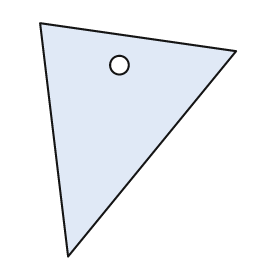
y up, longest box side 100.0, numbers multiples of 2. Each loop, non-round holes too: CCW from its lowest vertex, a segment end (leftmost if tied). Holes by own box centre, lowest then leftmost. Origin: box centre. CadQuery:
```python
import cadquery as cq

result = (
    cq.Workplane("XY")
    .moveTo(-30.0, -50.0)
    .lineTo(42.0, 38.0)
    .lineTo(-42.0, 50.0)
    .close()
    .moveTo(-8.0, 32.0)
    .circle(4.0)
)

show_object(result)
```